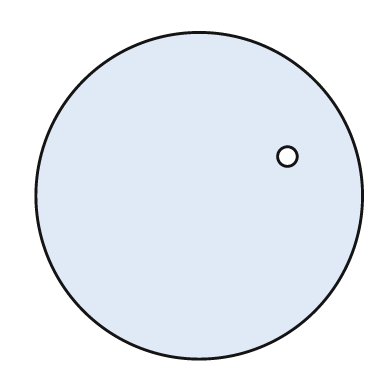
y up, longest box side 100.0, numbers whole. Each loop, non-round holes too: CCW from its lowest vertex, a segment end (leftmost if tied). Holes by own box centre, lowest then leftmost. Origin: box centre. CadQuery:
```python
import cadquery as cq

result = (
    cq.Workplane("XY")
    .moveTo(0.0, 0.0)
    .circle(50.0)
    .moveTo(27.0, 12.0)
    .circle(3.0)
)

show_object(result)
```